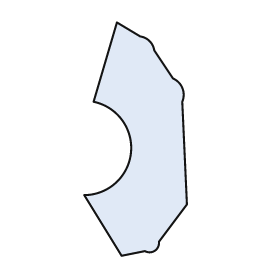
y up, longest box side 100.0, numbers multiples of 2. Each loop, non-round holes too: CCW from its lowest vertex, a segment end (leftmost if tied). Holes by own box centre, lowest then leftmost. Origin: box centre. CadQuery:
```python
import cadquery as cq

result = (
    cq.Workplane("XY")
    .moveTo(-6.0, -50.0)
    .lineTo(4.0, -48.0)
    .threePointArc((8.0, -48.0), (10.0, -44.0))
    .lineTo(22.0, -28.0)
    .lineTo(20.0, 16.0)
    .threePointArc((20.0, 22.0), (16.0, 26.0))
    .lineTo(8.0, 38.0)
    .threePointArc((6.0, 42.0), (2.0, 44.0))
    .lineTo(-8.0, 50.0)
    .lineTo(-18.0, 16.0)
    .threePointArc((-2.0, -6.0), (-22.0, -24.0))
    .close()
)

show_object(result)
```